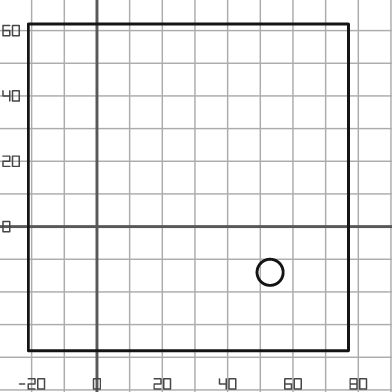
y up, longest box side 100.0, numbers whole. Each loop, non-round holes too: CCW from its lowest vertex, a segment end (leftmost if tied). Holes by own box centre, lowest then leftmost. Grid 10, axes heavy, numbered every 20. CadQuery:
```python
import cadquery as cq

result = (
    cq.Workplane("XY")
    .moveTo(-21.0, -38.0)
    .lineTo(77.0, -38.0)
    .lineTo(77.0, 62.0)
    .lineTo(-21.0, 62.0)
    .close()
    .moveTo(53.0, -14.0)
    .circle(4.0)
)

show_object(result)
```